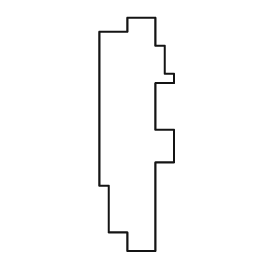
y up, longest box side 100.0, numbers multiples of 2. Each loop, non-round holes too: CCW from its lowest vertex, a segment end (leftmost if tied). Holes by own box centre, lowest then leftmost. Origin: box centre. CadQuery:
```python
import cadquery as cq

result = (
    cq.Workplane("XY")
    .moveTo(-4.0, -50.0)
    .lineTo(8.0, -50.0)
    .lineTo(8.0, -12.0)
    .lineTo(16.0, -12.0)
    .lineTo(16.0, 2.0)
    .lineTo(8.0, 2.0)
    .lineTo(8.0, 22.0)
    .lineTo(16.0, 22.0)
    .lineTo(16.0, 26.0)
    .lineTo(12.0, 26.0)
    .lineTo(12.0, 38.0)
    .lineTo(8.0, 38.0)
    .lineTo(8.0, 50.0)
    .lineTo(-4.0, 50.0)
    .lineTo(-4.0, 44.0)
    .lineTo(-16.0, 44.0)
    .lineTo(-16.0, -22.0)
    .lineTo(-12.0, -22.0)
    .lineTo(-12.0, -42.0)
    .lineTo(-4.0, -42.0)
    .close()
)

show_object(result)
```